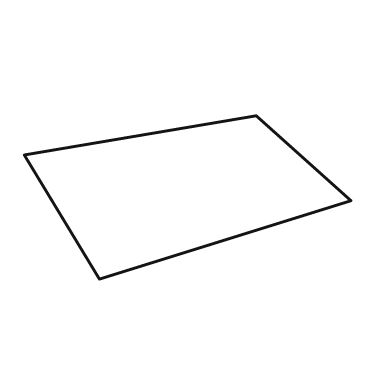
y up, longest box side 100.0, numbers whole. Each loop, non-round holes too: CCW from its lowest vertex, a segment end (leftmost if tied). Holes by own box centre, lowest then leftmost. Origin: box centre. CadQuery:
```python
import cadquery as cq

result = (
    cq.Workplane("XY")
    .moveTo(-27.0, -25.0)
    .lineTo(50.0, -1.0)
    .lineTo(21.0, 25.0)
    .lineTo(-50.0, 13.0)
    .close()
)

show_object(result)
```